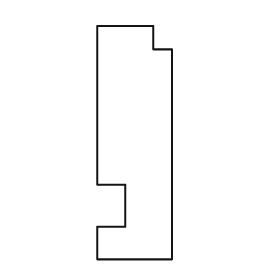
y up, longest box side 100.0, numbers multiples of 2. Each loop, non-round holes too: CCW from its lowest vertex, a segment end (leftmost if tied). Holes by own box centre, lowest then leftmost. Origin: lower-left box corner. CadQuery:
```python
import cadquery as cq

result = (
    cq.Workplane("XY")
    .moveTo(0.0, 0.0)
    .lineTo(32.0, 0.0)
    .lineTo(32.0, 90.0)
    .lineTo(24.0, 90.0)
    .lineTo(24.0, 100.0)
    .lineTo(0.0, 100.0)
    .lineTo(0.0, 32.0)
    .lineTo(12.0, 32.0)
    .lineTo(12.0, 14.0)
    .lineTo(0.0, 14.0)
    .close()
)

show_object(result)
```